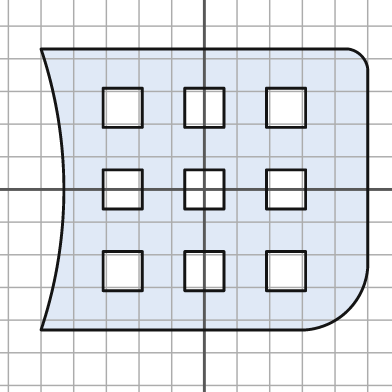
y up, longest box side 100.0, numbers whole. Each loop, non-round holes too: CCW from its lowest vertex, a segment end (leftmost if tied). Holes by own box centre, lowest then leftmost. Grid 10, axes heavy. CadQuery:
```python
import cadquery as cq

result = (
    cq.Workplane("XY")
    .moveTo(-50.0, -43.0)
    .lineTo(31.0, -43.0)
    .threePointArc((44.0, -37.0), (50.0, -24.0))
    .lineTo(50.0, 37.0)
    .threePointArc((48.0, 41.0), (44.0, 43.0))
    .lineTo(-50.0, 43.0)
    .threePointArc((-43.0, 0.0), (-50.0, -43.0))
    .close()
    .moveTo(-31.0, -31.0)
    .lineTo(-19.0, -31.0)
    .lineTo(-19.0, -19.0)
    .lineTo(-31.0, -19.0)
    .close()
    .moveTo(-6.0, -31.0)
    .lineTo(6.0, -31.0)
    .lineTo(6.0, -19.0)
    .lineTo(-6.0, -19.0)
    .close()
    .moveTo(19.0, -31.0)
    .lineTo(31.0, -31.0)
    .lineTo(31.0, -19.0)
    .lineTo(19.0, -19.0)
    .close()
    .moveTo(-31.0, -6.0)
    .lineTo(-19.0, -6.0)
    .lineTo(-19.0, 6.0)
    .lineTo(-31.0, 6.0)
    .close()
    .moveTo(-6.0, -6.0)
    .lineTo(6.0, -6.0)
    .lineTo(6.0, 6.0)
    .lineTo(-6.0, 6.0)
    .close()
    .moveTo(19.0, -6.0)
    .lineTo(31.0, -6.0)
    .lineTo(31.0, 6.0)
    .lineTo(19.0, 6.0)
    .close()
    .moveTo(-31.0, 19.0)
    .lineTo(-19.0, 19.0)
    .lineTo(-19.0, 31.0)
    .lineTo(-31.0, 31.0)
    .close()
    .moveTo(-6.0, 19.0)
    .lineTo(6.0, 19.0)
    .lineTo(6.0, 31.0)
    .lineTo(-6.0, 31.0)
    .close()
    .moveTo(19.0, 19.0)
    .lineTo(31.0, 19.0)
    .lineTo(31.0, 31.0)
    .lineTo(19.0, 31.0)
    .close()
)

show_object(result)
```